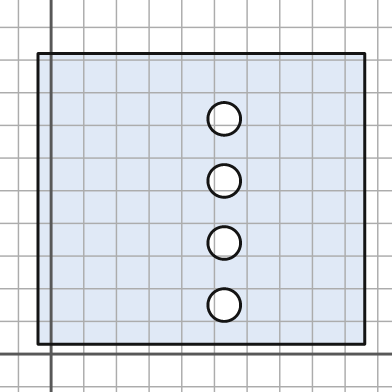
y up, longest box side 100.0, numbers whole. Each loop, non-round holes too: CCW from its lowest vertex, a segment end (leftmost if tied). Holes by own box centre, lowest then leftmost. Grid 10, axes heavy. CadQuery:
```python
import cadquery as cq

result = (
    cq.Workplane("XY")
    .moveTo(-4.0, 3.0)
    .lineTo(96.0, 3.0)
    .lineTo(96.0, 92.0)
    .lineTo(-4.0, 92.0)
    .close()
    .moveTo(53.0, 15.0)
    .circle(5.0)
    .moveTo(53.0, 34.0)
    .circle(5.0)
    .moveTo(53.0, 53.0)
    .circle(5.0)
    .moveTo(53.0, 72.0)
    .circle(5.0)
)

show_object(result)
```